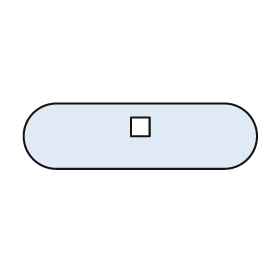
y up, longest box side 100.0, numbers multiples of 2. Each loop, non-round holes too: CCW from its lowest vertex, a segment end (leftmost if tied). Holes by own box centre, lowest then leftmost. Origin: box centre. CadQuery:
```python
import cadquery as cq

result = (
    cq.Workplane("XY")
    .moveTo(-36.0, -14.0)
    .lineTo(36.0, -14.0)
    .threePointArc((50.0, 0.0), (36.0, 14.0))
    .lineTo(-36.0, 14.0)
    .threePointArc((-50.0, 0.0), (-36.0, -14.0))
    .close()
    .moveTo(-4.0, 0.0)
    .lineTo(4.0, 0.0)
    .lineTo(4.0, 8.0)
    .lineTo(-4.0, 8.0)
    .close()
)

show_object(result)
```